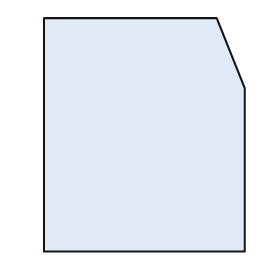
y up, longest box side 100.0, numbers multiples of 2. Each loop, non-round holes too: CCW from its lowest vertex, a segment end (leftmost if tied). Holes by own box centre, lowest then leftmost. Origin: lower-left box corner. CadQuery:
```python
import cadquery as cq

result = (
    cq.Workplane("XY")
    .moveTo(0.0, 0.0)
    .lineTo(86.0, 0.0)
    .lineTo(86.0, 70.0)
    .lineTo(74.0, 100.0)
    .lineTo(0.0, 100.0)
    .close()
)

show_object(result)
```